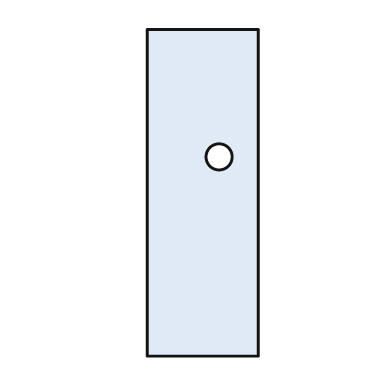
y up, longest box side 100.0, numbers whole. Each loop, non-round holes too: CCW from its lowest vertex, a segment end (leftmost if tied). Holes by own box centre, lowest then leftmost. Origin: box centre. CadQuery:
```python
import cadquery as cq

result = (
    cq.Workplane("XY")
    .moveTo(-17.0, -50.0)
    .lineTo(17.0, -50.0)
    .lineTo(17.0, 50.0)
    .lineTo(-17.0, 50.0)
    .close()
    .moveTo(5.0, 11.0)
    .circle(4.0)
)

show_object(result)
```